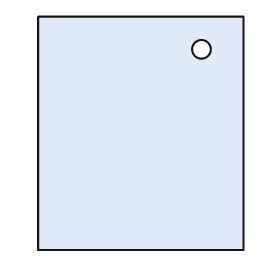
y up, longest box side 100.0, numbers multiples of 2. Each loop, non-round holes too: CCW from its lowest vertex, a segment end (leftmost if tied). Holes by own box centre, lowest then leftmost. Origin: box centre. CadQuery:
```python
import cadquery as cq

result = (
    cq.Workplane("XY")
    .moveTo(-44.0, -50.0)
    .lineTo(44.0, -50.0)
    .lineTo(44.0, 50.0)
    .lineTo(-44.0, 50.0)
    .close()
    .moveTo(26.0, 36.0)
    .circle(4.0)
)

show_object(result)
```